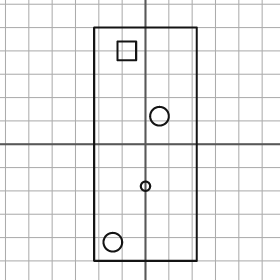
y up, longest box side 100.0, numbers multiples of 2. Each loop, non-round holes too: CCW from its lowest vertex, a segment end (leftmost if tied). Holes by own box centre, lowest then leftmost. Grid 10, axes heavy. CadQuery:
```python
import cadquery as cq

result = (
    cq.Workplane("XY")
    .moveTo(-22.0, -50.0)
    .lineTo(22.0, -50.0)
    .lineTo(22.0, 50.0)
    .lineTo(-22.0, 50.0)
    .close()
    .moveTo(-14.0, -42.0)
    .circle(4.0)
    .moveTo(0.0, -18.0)
    .circle(2.0)
    .moveTo(6.0, 12.0)
    .circle(4.0)
    .moveTo(-12.0, 36.0)
    .lineTo(-4.0, 36.0)
    .lineTo(-4.0, 44.0)
    .lineTo(-12.0, 44.0)
    .close()
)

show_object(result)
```